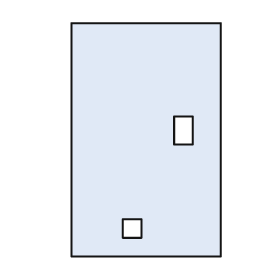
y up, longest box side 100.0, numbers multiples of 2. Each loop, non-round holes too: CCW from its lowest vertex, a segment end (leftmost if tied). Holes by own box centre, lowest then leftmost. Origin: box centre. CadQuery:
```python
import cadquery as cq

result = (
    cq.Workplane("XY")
    .moveTo(-32.0, -50.0)
    .lineTo(32.0, -50.0)
    .lineTo(32.0, 50.0)
    .lineTo(-32.0, 50.0)
    .close()
    .moveTo(-10.0, -42.0)
    .lineTo(-2.0, -42.0)
    .lineTo(-2.0, -34.0)
    .lineTo(-10.0, -34.0)
    .close()
    .moveTo(12.0, -2.0)
    .lineTo(20.0, -2.0)
    .lineTo(20.0, 10.0)
    .lineTo(12.0, 10.0)
    .close()
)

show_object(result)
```